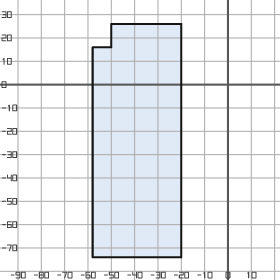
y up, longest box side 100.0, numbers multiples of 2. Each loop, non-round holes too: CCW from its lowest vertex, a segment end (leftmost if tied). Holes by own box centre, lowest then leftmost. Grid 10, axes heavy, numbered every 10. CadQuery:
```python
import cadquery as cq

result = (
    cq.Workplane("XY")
    .moveTo(-58.0, -74.0)
    .lineTo(-20.0, -74.0)
    .lineTo(-20.0, 26.0)
    .lineTo(-50.0, 26.0)
    .lineTo(-50.0, 16.0)
    .lineTo(-58.0, 16.0)
    .close()
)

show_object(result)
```